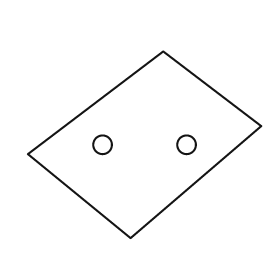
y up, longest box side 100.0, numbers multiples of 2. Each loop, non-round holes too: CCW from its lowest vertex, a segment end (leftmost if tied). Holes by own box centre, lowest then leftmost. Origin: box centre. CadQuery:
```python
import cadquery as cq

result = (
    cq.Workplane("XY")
    .moveTo(-6.0, -40.0)
    .lineTo(50.0, 8.0)
    .lineTo(8.0, 40.0)
    .lineTo(-50.0, -4.0)
    .close()
    .moveTo(-18.0, 0.0)
    .circle(4.0)
    .moveTo(18.0, 0.0)
    .circle(4.0)
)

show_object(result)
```